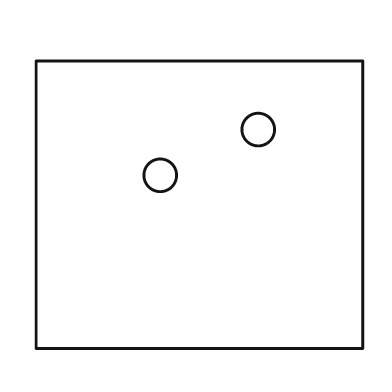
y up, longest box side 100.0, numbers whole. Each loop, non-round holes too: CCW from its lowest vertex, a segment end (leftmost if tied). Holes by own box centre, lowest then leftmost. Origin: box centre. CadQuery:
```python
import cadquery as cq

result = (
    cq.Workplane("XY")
    .moveTo(-50.0, -44.0)
    .lineTo(50.0, -44.0)
    .lineTo(50.0, 44.0)
    .lineTo(-50.0, 44.0)
    .close()
    .moveTo(-12.0, 9.0)
    .circle(5.0)
    .moveTo(18.0, 23.0)
    .circle(5.0)
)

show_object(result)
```